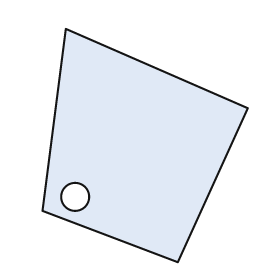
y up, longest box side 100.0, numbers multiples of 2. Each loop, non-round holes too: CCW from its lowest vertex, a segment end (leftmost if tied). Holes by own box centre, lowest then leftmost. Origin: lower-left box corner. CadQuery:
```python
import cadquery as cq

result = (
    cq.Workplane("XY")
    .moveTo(58.0, 0.0)
    .lineTo(88.0, 66.0)
    .lineTo(10.0, 100.0)
    .lineTo(0.0, 22.0)
    .close()
    .moveTo(14.0, 28.0)
    .circle(6.0)
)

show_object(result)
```